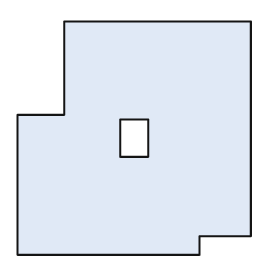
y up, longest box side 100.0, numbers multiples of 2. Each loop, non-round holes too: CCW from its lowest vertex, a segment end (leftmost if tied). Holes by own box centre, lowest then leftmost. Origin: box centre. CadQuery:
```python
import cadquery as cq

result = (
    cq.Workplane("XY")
    .moveTo(-50.0, -50.0)
    .lineTo(28.0, -50.0)
    .lineTo(28.0, -42.0)
    .lineTo(50.0, -42.0)
    .lineTo(50.0, 50.0)
    .lineTo(-30.0, 50.0)
    .lineTo(-30.0, 10.0)
    .lineTo(-50.0, 10.0)
    .close()
    .moveTo(-6.0, -8.0)
    .lineTo(6.0, -8.0)
    .lineTo(6.0, 8.0)
    .lineTo(-6.0, 8.0)
    .close()
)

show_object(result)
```